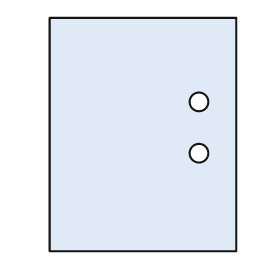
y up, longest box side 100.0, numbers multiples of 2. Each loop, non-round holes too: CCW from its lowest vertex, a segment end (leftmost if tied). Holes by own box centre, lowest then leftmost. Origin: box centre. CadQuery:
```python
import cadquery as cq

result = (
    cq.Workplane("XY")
    .moveTo(-40.0, -50.0)
    .lineTo(40.0, -50.0)
    .lineTo(40.0, 50.0)
    .lineTo(-40.0, 50.0)
    .close()
    .moveTo(24.0, -8.0)
    .circle(4.0)
    .moveTo(24.0, 14.0)
    .circle(4.0)
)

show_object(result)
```